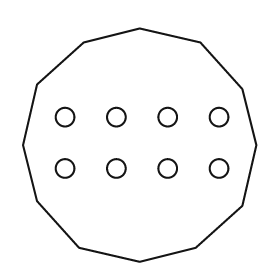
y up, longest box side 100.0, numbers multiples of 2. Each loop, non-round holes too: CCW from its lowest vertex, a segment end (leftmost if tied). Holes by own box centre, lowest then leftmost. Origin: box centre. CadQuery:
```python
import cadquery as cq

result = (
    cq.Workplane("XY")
    .moveTo(0.0, -50.0)
    .lineTo(24.0, -44.0)
    .lineTo(44.0, -26.0)
    .lineTo(50.0, 0.0)
    .lineTo(44.0, 24.0)
    .lineTo(26.0, 44.0)
    .lineTo(0.0, 50.0)
    .lineTo(-24.0, 44.0)
    .lineTo(-44.0, 26.0)
    .lineTo(-50.0, 0.0)
    .lineTo(-44.0, -24.0)
    .lineTo(-26.0, -44.0)
    .close()
    .moveTo(-32.0, -10.0)
    .circle(4.0)
    .moveTo(-10.0, -10.0)
    .circle(4.0)
    .moveTo(12.0, -10.0)
    .circle(4.0)
    .moveTo(34.0, -10.0)
    .circle(4.0)
    .moveTo(-32.0, 12.0)
    .circle(4.0)
    .moveTo(-10.0, 12.0)
    .circle(4.0)
    .moveTo(12.0, 12.0)
    .circle(4.0)
    .moveTo(34.0, 12.0)
    .circle(4.0)
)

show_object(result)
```